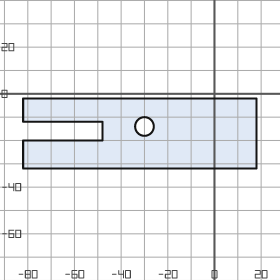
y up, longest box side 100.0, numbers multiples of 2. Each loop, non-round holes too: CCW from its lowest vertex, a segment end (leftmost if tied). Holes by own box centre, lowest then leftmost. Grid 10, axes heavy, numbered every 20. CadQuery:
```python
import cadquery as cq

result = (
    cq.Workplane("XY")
    .moveTo(-82.0, -32.0)
    .lineTo(18.0, -32.0)
    .lineTo(18.0, -2.0)
    .lineTo(-82.0, -2.0)
    .lineTo(-82.0, -12.0)
    .lineTo(-48.0, -12.0)
    .lineTo(-48.0, -20.0)
    .lineTo(-82.0, -20.0)
    .close()
    .moveTo(-30.0, -14.0)
    .circle(4.0)
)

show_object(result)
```